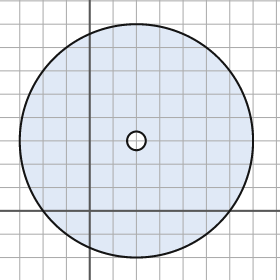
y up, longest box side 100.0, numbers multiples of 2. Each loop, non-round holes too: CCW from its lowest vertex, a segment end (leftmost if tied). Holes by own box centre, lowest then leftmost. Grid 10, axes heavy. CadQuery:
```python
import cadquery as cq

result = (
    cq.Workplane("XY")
    .moveTo(20.0, 30.0)
    .circle(50.0)
    .moveTo(20.0, 30.0)
    .circle(4.0)
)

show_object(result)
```